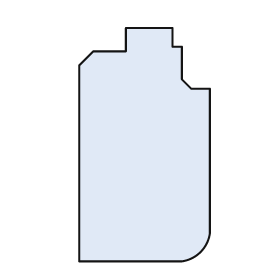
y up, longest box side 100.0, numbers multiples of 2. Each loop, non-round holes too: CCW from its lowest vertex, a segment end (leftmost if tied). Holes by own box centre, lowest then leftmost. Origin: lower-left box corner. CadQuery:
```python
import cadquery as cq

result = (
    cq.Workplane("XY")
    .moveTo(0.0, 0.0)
    .lineTo(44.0, 0.0)
    .threePointArc((52.0, 4.0), (56.0, 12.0))
    .lineTo(56.0, 74.0)
    .lineTo(48.0, 74.0)
    .lineTo(44.0, 78.0)
    .lineTo(44.0, 92.0)
    .lineTo(40.0, 92.0)
    .lineTo(40.0, 100.0)
    .lineTo(20.0, 100.0)
    .lineTo(20.0, 90.0)
    .lineTo(6.0, 90.0)
    .lineTo(0.0, 84.0)
    .close()
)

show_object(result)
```